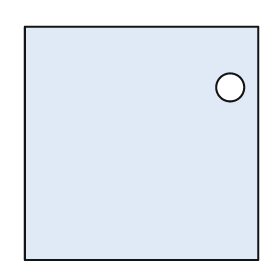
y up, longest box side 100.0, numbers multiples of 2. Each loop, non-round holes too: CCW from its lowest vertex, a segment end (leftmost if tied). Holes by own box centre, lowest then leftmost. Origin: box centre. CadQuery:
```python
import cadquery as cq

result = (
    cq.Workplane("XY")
    .moveTo(-50.0, -50.0)
    .lineTo(50.0, -50.0)
    .lineTo(50.0, 50.0)
    .lineTo(-50.0, 50.0)
    .close()
    .moveTo(38.0, 24.0)
    .circle(6.0)
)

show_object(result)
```